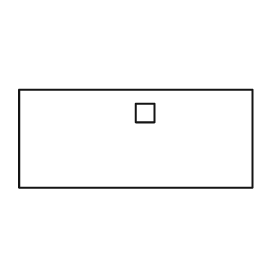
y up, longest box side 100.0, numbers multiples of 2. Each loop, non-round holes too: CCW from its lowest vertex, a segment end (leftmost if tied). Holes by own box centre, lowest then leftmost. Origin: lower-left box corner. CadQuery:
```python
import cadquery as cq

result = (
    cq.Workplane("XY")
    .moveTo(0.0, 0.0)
    .lineTo(100.0, 0.0)
    .lineTo(100.0, 42.0)
    .lineTo(0.0, 42.0)
    .close()
    .moveTo(50.0, 28.0)
    .lineTo(58.0, 28.0)
    .lineTo(58.0, 36.0)
    .lineTo(50.0, 36.0)
    .close()
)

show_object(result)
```